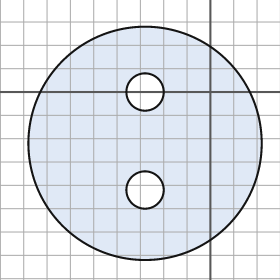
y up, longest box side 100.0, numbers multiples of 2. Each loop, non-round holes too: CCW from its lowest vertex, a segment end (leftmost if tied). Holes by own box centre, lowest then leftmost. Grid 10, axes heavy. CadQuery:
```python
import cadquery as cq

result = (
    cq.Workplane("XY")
    .moveTo(-28.0, -22.0)
    .circle(50.0)
    .moveTo(-28.0, -42.0)
    .circle(8.0)
    .moveTo(-28.0, 0.0)
    .circle(8.0)
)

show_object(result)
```